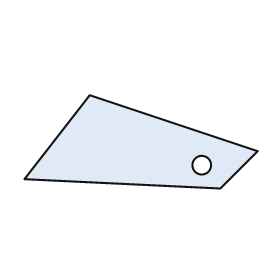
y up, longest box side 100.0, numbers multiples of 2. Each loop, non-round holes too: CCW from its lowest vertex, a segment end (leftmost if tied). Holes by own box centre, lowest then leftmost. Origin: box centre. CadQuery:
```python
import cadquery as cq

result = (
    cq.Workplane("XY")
    .moveTo(34.0, -20.0)
    .lineTo(50.0, -4.0)
    .lineTo(-22.0, 20.0)
    .lineTo(-50.0, -16.0)
    .close()
    .moveTo(26.0, -10.0)
    .circle(4.0)
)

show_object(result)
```